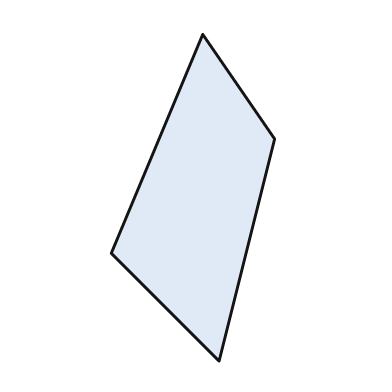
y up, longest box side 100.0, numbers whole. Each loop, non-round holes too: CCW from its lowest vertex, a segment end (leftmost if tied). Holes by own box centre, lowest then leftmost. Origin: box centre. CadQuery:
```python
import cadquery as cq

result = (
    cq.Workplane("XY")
    .moveTo(8.0, -50.0)
    .lineTo(25.0, 18.0)
    .lineTo(3.0, 50.0)
    .lineTo(-25.0, -17.0)
    .close()
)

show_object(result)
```